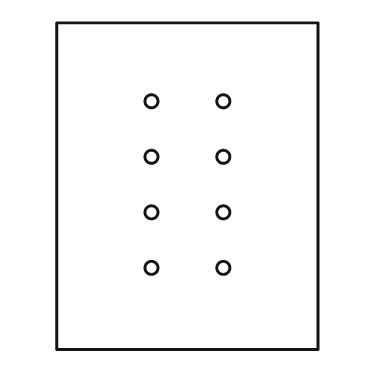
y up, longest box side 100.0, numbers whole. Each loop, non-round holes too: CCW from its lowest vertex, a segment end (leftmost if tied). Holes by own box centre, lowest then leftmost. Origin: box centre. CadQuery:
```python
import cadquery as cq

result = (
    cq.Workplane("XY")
    .moveTo(-40.0, -50.0)
    .lineTo(40.0, -50.0)
    .lineTo(40.0, 50.0)
    .lineTo(-40.0, 50.0)
    .close()
    .moveTo(-11.0, -25.0)
    .circle(2.0)
    .moveTo(11.0, -25.0)
    .circle(2.0)
    .moveTo(-11.0, -8.0)
    .circle(2.0)
    .moveTo(11.0, -8.0)
    .circle(2.0)
    .moveTo(-11.0, 9.0)
    .circle(2.0)
    .moveTo(11.0, 9.0)
    .circle(2.0)
    .moveTo(-11.0, 26.0)
    .circle(2.0)
    .moveTo(11.0, 26.0)
    .circle(2.0)
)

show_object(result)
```